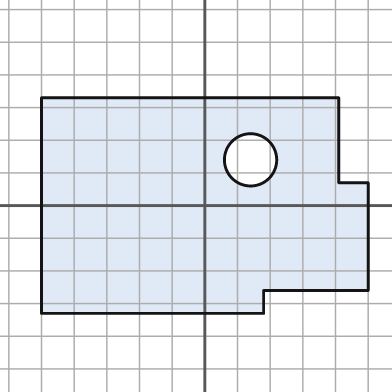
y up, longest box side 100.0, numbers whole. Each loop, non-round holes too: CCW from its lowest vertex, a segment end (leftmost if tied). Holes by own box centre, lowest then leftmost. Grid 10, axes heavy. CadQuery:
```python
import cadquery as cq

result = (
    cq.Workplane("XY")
    .moveTo(-50.0, -33.0)
    .lineTo(18.0, -33.0)
    .lineTo(18.0, -26.0)
    .lineTo(50.0, -26.0)
    .lineTo(50.0, 7.0)
    .lineTo(41.0, 7.0)
    .lineTo(41.0, 33.0)
    .lineTo(-50.0, 33.0)
    .close()
    .moveTo(14.0, 14.0)
    .circle(8.0)
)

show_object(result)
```